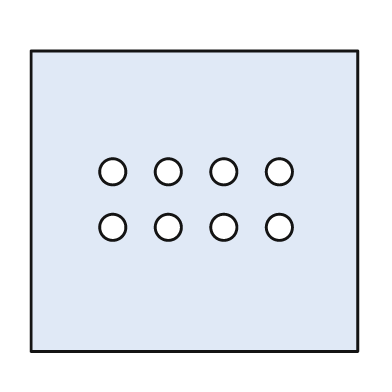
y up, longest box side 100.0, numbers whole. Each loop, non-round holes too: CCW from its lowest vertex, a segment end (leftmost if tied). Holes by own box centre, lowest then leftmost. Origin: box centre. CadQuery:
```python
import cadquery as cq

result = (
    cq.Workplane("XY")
    .moveTo(-50.0, -46.0)
    .lineTo(50.0, -46.0)
    .lineTo(50.0, 46.0)
    .lineTo(-50.0, 46.0)
    .close()
    .moveTo(-25.0, -8.0)
    .circle(4.0)
    .moveTo(-8.0, -8.0)
    .circle(4.0)
    .moveTo(9.0, -8.0)
    .circle(4.0)
    .moveTo(26.0, -8.0)
    .circle(4.0)
    .moveTo(-25.0, 9.0)
    .circle(4.0)
    .moveTo(-8.0, 9.0)
    .circle(4.0)
    .moveTo(9.0, 9.0)
    .circle(4.0)
    .moveTo(26.0, 9.0)
    .circle(4.0)
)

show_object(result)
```